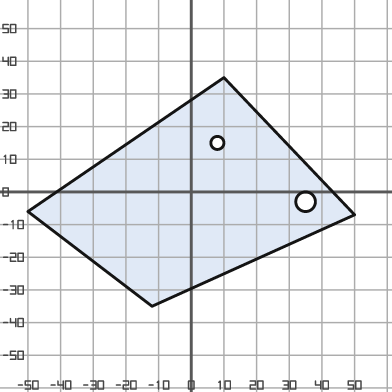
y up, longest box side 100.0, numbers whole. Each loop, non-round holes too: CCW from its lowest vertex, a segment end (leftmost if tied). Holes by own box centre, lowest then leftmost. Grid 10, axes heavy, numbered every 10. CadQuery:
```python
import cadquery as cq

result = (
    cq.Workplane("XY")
    .moveTo(-12.0, -35.0)
    .lineTo(50.0, -7.0)
    .lineTo(10.0, 35.0)
    .lineTo(-50.0, -6.0)
    .close()
    .moveTo(35.0, -3.0)
    .circle(3.0)
    .moveTo(8.0, 15.0)
    .circle(2.0)
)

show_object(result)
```